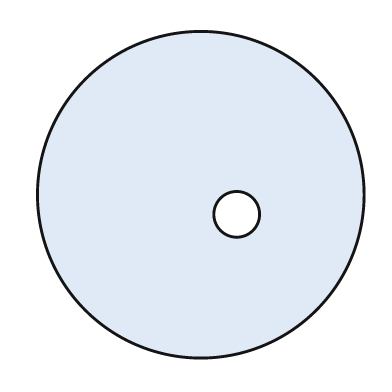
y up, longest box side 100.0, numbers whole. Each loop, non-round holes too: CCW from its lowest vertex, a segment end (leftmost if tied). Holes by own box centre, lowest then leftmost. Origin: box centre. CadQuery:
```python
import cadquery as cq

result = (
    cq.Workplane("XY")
    .moveTo(0.0, 0.0)
    .circle(50.0)
    .moveTo(11.0, -6.0)
    .circle(7.0)
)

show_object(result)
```